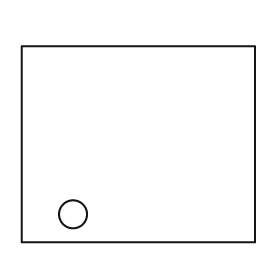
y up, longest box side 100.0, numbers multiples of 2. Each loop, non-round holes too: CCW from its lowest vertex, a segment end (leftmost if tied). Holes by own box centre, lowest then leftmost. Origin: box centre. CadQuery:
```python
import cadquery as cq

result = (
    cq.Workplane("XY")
    .moveTo(-50.0, -42.0)
    .lineTo(50.0, -42.0)
    .lineTo(50.0, 42.0)
    .lineTo(-50.0, 42.0)
    .close()
    .moveTo(-28.0, -30.0)
    .circle(6.0)
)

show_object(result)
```